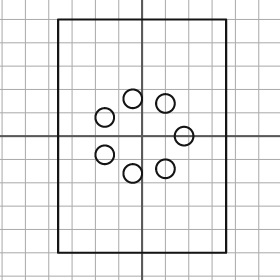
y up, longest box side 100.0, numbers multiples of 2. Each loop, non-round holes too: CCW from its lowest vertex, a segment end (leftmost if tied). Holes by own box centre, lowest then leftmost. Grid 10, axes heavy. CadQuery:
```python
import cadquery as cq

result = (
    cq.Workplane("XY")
    .moveTo(-36.0, -50.0)
    .lineTo(36.0, -50.0)
    .lineTo(36.0, 50.0)
    .lineTo(-36.0, 50.0)
    .close()
    .moveTo(-4.0, -16.0)
    .circle(4.0)
    .moveTo(10.0, -14.0)
    .circle(4.0)
    .moveTo(-16.0, -8.0)
    .circle(4.0)
    .moveTo(18.0, 0.0)
    .circle(4.0)
    .moveTo(-16.0, 8.0)
    .circle(4.0)
    .moveTo(10.0, 14.0)
    .circle(4.0)
    .moveTo(-4.0, 16.0)
    .circle(4.0)
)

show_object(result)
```